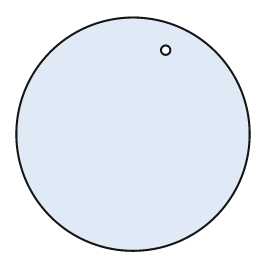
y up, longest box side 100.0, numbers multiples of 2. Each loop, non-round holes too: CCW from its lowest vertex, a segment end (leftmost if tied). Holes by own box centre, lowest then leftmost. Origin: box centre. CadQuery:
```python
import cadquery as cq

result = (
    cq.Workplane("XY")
    .moveTo(0.0, 0.0)
    .circle(50.0)
    .moveTo(14.0, 36.0)
    .circle(2.0)
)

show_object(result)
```